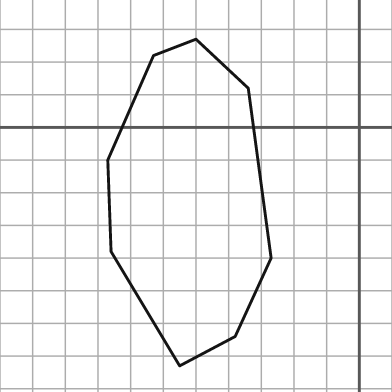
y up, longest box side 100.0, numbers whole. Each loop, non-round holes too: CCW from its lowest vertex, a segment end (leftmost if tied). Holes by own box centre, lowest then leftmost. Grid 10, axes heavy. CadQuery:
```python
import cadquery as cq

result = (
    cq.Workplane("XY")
    .moveTo(-55.0, -73.0)
    .lineTo(-38.0, -64.0)
    .lineTo(-27.0, -40.0)
    .lineTo(-34.0, 12.0)
    .lineTo(-50.0, 27.0)
    .lineTo(-63.0, 22.0)
    .lineTo(-77.0, -10.0)
    .lineTo(-76.0, -38.0)
    .close()
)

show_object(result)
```